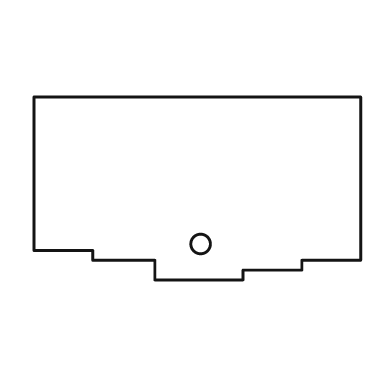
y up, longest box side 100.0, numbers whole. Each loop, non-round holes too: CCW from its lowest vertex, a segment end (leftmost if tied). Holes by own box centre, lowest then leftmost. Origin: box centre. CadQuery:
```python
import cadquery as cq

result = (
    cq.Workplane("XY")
    .moveTo(-13.0, -28.0)
    .lineTo(14.0, -28.0)
    .lineTo(14.0, -25.0)
    .lineTo(32.0, -25.0)
    .lineTo(32.0, -22.0)
    .lineTo(50.0, -22.0)
    .lineTo(50.0, 28.0)
    .lineTo(-50.0, 28.0)
    .lineTo(-50.0, -19.0)
    .lineTo(-32.0, -19.0)
    .lineTo(-32.0, -22.0)
    .lineTo(-13.0, -22.0)
    .close()
    .moveTo(1.0, -17.0)
    .circle(3.0)
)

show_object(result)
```